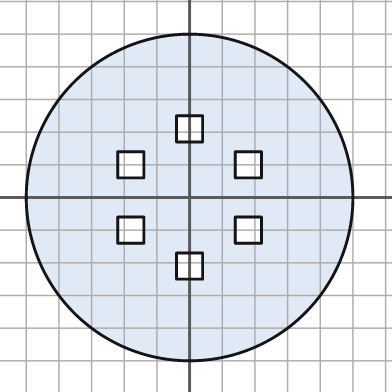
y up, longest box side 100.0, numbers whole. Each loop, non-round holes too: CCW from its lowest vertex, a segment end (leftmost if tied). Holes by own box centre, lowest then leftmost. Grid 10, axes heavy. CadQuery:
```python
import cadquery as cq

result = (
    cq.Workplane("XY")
    .moveTo(0.0, 0.0)
    .circle(50.0)
    .moveTo(-4.0, -25.0)
    .lineTo(4.0, -25.0)
    .lineTo(4.0, -17.0)
    .lineTo(-4.0, -17.0)
    .close()
    .moveTo(-22.0, -14.0)
    .lineTo(-14.0, -14.0)
    .lineTo(-14.0, -6.0)
    .lineTo(-22.0, -6.0)
    .close()
    .moveTo(14.0, -14.0)
    .lineTo(22.0, -14.0)
    .lineTo(22.0, -6.0)
    .lineTo(14.0, -6.0)
    .close()
    .moveTo(-22.0, 6.0)
    .lineTo(-14.0, 6.0)
    .lineTo(-14.0, 14.0)
    .lineTo(-22.0, 14.0)
    .close()
    .moveTo(14.0, 6.0)
    .lineTo(22.0, 6.0)
    .lineTo(22.0, 14.0)
    .lineTo(14.0, 14.0)
    .close()
    .moveTo(-4.0, 17.0)
    .lineTo(4.0, 17.0)
    .lineTo(4.0, 25.0)
    .lineTo(-4.0, 25.0)
    .close()
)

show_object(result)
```